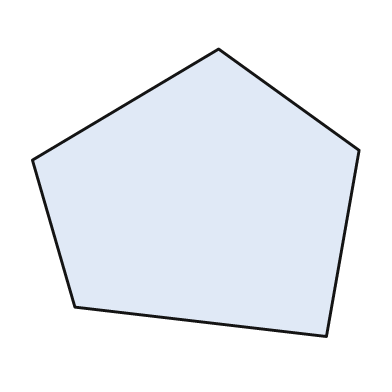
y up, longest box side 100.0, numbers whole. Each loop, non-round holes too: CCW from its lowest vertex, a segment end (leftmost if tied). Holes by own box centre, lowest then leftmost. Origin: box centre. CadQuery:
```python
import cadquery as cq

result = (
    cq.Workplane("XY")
    .moveTo(40.0, -44.0)
    .lineTo(50.0, 13.0)
    .lineTo(7.0, 44.0)
    .lineTo(-50.0, 10.0)
    .lineTo(-37.0, -35.0)
    .close()
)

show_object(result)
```